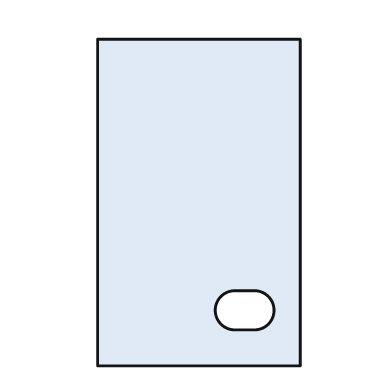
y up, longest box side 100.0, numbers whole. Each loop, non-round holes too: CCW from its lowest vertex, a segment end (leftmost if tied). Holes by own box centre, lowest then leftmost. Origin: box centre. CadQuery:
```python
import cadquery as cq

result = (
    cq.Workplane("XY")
    .moveTo(-31.0, -50.0)
    .lineTo(31.0, -50.0)
    .lineTo(31.0, 50.0)
    .lineTo(-31.0, 50.0)
    .close()
    .moveTo(11.0, -39.0)
    .lineTo(17.0, -39.0)
    .threePointArc((23.0, -33.0), (17.0, -27.0))
    .lineTo(11.0, -27.0)
    .threePointArc((5.0, -33.0), (11.0, -39.0))
    .close()
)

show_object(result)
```